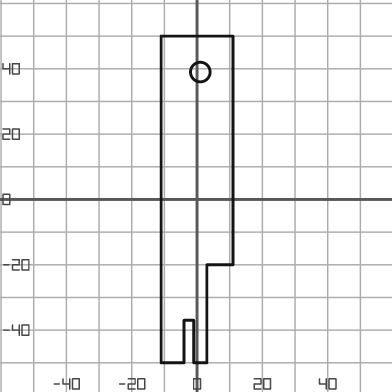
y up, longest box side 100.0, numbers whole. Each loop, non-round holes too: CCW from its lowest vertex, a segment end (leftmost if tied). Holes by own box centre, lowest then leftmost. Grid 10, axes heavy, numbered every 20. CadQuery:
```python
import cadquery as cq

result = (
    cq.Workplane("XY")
    .moveTo(-11.0, -50.0)
    .lineTo(-4.0, -50.0)
    .lineTo(-4.0, -37.0)
    .lineTo(-1.0, -37.0)
    .lineTo(-1.0, -50.0)
    .lineTo(3.0, -50.0)
    .lineTo(3.0, -20.0)
    .lineTo(11.0, -20.0)
    .lineTo(11.0, 50.0)
    .lineTo(-11.0, 50.0)
    .close()
    .moveTo(1.0, 39.0)
    .circle(3.0)
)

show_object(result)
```